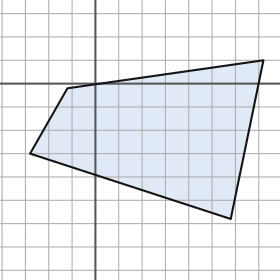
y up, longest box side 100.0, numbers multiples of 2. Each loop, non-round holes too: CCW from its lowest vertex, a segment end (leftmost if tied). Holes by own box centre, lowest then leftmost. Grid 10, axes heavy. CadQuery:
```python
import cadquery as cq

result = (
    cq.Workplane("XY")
    .moveTo(58.0, -58.0)
    .lineTo(72.0, 10.0)
    .lineTo(-12.0, -2.0)
    .lineTo(-28.0, -30.0)
    .close()
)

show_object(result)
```